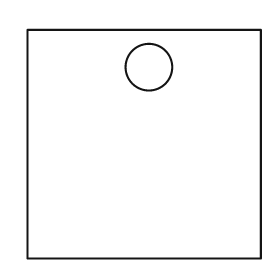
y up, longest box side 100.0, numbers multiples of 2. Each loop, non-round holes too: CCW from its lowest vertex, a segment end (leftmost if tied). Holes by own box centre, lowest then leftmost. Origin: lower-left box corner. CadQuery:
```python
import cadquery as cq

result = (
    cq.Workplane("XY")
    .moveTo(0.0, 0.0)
    .lineTo(100.0, 0.0)
    .lineTo(100.0, 98.0)
    .lineTo(0.0, 98.0)
    .close()
    .moveTo(52.0, 82.0)
    .circle(10.0)
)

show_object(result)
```